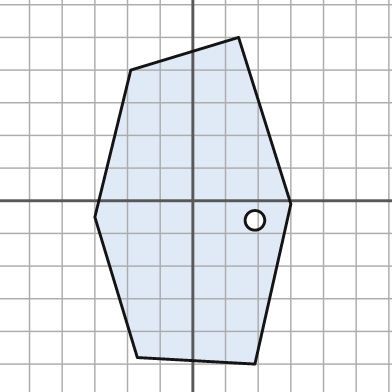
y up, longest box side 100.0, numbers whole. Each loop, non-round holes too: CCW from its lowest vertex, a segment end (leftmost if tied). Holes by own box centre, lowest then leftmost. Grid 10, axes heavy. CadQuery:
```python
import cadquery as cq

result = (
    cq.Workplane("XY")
    .moveTo(19.0, -50.0)
    .lineTo(30.0, -1.0)
    .lineTo(14.0, 50.0)
    .lineTo(-19.0, 40.0)
    .lineTo(-30.0, -5.0)
    .lineTo(-17.0, -48.0)
    .close()
    .moveTo(19.0, -6.0)
    .circle(3.0)
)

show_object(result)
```